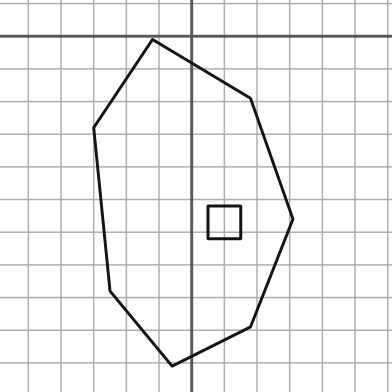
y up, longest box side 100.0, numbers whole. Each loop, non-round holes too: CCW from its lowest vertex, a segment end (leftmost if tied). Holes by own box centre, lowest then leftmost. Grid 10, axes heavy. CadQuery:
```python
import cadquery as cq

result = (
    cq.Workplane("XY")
    .moveTo(-6.0, -101.0)
    .lineTo(18.0, -89.0)
    .lineTo(31.0, -56.0)
    .lineTo(18.0, -19.0)
    .lineTo(-12.0, -1.0)
    .lineTo(-30.0, -28.0)
    .lineTo(-25.0, -78.0)
    .close()
    .moveTo(5.0, -62.0)
    .lineTo(15.0, -62.0)
    .lineTo(15.0, -52.0)
    .lineTo(5.0, -52.0)
    .close()
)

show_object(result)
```